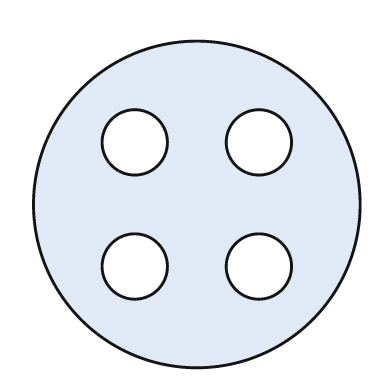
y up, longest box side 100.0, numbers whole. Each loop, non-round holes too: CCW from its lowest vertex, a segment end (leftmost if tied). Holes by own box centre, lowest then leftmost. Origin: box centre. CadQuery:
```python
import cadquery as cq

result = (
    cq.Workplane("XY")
    .moveTo(0.0, 0.0)
    .circle(50.0)
    .moveTo(-19.0, -19.0)
    .circle(10.0)
    .moveTo(19.0, -19.0)
    .circle(10.0)
    .moveTo(-19.0, 19.0)
    .circle(10.0)
    .moveTo(19.0, 19.0)
    .circle(10.0)
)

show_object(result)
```